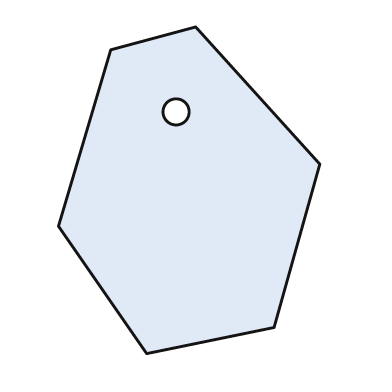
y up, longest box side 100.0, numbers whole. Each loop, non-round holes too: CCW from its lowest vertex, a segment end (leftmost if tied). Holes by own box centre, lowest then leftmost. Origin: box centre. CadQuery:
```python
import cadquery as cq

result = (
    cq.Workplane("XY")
    .moveTo(-13.0, -50.0)
    .lineTo(26.0, -42.0)
    .lineTo(40.0, 8.0)
    .lineTo(2.0, 50.0)
    .lineTo(-24.0, 43.0)
    .lineTo(-40.0, -11.0)
    .close()
    .moveTo(-4.0, 24.0)
    .circle(4.0)
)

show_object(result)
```